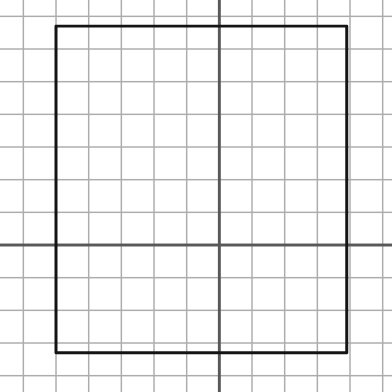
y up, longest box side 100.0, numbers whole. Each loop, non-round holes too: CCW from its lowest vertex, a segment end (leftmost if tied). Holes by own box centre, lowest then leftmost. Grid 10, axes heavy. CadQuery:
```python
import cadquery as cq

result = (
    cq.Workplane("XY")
    .moveTo(-50.0, -33.0)
    .lineTo(39.0, -33.0)
    .lineTo(39.0, 67.0)
    .lineTo(-50.0, 67.0)
    .close()
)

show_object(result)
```